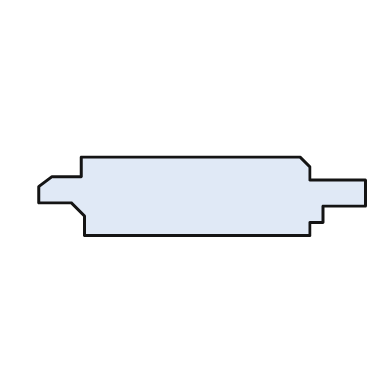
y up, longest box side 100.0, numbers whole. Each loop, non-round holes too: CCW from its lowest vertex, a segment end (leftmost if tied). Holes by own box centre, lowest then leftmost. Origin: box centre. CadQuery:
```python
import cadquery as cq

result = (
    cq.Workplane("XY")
    .moveTo(-36.0, -12.0)
    .lineTo(33.0, -12.0)
    .lineTo(33.0, -8.0)
    .lineTo(37.0, -8.0)
    .lineTo(37.0, -3.0)
    .lineTo(50.0, -3.0)
    .lineTo(50.0, 5.0)
    .lineTo(33.0, 5.0)
    .lineTo(33.0, 9.0)
    .lineTo(30.0, 12.0)
    .lineTo(-37.0, 12.0)
    .lineTo(-37.0, 6.0)
    .lineTo(-46.0, 6.0)
    .lineTo(-50.0, 3.0)
    .lineTo(-50.0, -2.0)
    .lineTo(-40.0, -2.0)
    .lineTo(-36.0, -6.0)
    .close()
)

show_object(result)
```